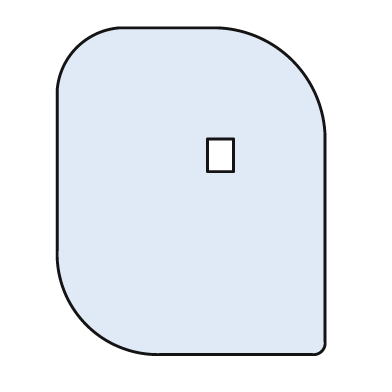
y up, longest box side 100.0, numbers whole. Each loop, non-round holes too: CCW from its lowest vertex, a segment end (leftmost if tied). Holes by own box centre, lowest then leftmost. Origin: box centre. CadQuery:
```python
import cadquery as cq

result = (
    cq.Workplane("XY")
    .moveTo(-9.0, -50.0)
    .lineTo(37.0, -50.0)
    .threePointArc((40.0, -49.0), (41.0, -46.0))
    .lineTo(41.0, 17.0)
    .threePointArc((31.0, 40.0), (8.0, 50.0))
    .lineTo(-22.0, 50.0)
    .threePointArc((-35.0, 44.0), (-41.0, 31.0))
    .lineTo(-41.0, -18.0)
    .threePointArc((-32.0, -41.0), (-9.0, -50.0))
    .close()
    .moveTo(5.0, 6.0)
    .lineTo(13.0, 6.0)
    .lineTo(13.0, 16.0)
    .lineTo(5.0, 16.0)
    .close()
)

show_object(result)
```